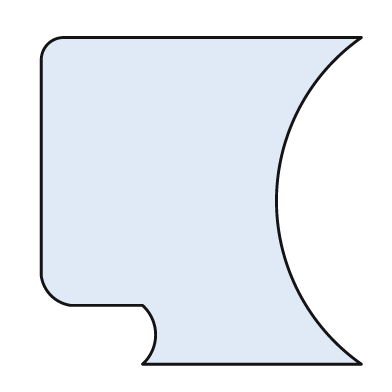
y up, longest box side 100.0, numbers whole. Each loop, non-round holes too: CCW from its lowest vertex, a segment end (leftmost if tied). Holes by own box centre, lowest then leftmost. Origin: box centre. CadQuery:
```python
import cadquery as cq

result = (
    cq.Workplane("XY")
    .moveTo(-18.0, -50.0)
    .lineTo(49.0, -50.0)
    .threePointArc((23.0, 0.0), (49.0, 50.0))
    .lineTo(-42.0, 50.0)
    .threePointArc((-47.0, 48.0), (-49.0, 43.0))
    .lineTo(-49.0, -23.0)
    .threePointArc((-46.0, -29.0), (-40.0, -32.0))
    .lineTo(-18.0, -32.0)
    .threePointArc((-14.0, -41.0), (-18.0, -50.0))
    .close()
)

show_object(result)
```